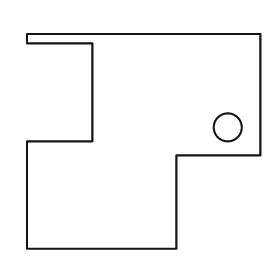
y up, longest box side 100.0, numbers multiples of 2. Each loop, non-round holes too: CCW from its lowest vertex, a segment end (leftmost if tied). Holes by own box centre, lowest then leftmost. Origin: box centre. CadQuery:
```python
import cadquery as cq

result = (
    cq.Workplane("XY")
    .moveTo(-50.0, -46.0)
    .lineTo(14.0, -46.0)
    .lineTo(14.0, -6.0)
    .lineTo(50.0, -6.0)
    .lineTo(50.0, 46.0)
    .lineTo(-50.0, 46.0)
    .lineTo(-50.0, 42.0)
    .lineTo(-22.0, 42.0)
    .lineTo(-22.0, 0.0)
    .lineTo(-50.0, 0.0)
    .close()
    .moveTo(36.0, 6.0)
    .circle(6.0)
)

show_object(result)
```